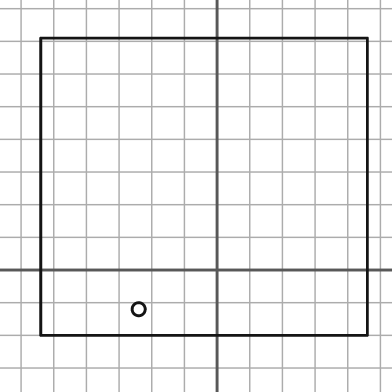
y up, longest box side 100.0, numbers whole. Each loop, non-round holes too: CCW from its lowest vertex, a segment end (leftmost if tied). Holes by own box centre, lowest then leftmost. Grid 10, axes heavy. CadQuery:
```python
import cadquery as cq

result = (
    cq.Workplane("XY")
    .moveTo(-54.0, -20.0)
    .lineTo(46.0, -20.0)
    .lineTo(46.0, 71.0)
    .lineTo(-54.0, 71.0)
    .close()
    .moveTo(-24.0, -12.0)
    .circle(2.0)
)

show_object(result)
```